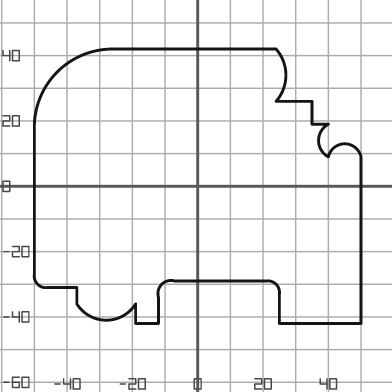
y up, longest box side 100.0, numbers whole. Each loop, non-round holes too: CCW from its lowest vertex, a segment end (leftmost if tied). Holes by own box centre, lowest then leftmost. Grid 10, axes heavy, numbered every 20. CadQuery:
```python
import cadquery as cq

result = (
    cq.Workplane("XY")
    .moveTo(-19.0, -42.0)
    .lineTo(-12.0, -42.0)
    .lineTo(-12.0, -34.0)
    .threePointArc((-11.0, -30.0), (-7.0, -29.0))
    .lineTo(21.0, -29.0)
    .threePointArc((24.0, -30.0), (25.0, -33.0))
    .lineTo(25.0, -42.0)
    .lineTo(50.0, -42.0)
    .lineTo(50.0, 9.0)
    .threePointArc((45.0, 13.0), (40.0, 9.0))
    .threePointArc((37.0, 14.0), (40.0, 19.0))
    .lineTo(35.0, 19.0)
    .lineTo(35.0, 26.0)
    .lineTo(24.0, 26.0)
    .threePointArc((27.0, 34.0), (24.0, 42.0))
    .lineTo(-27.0, 42.0)
    .threePointArc((-43.0, 35.0), (-50.0, 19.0))
    .lineTo(-50.0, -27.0)
    .threePointArc((-49.0, -30.0), (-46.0, -31.0))
    .lineTo(-37.0, -31.0)
    .lineTo(-37.0, -36.0)
    .threePointArc((-28.0, -41.0), (-19.0, -36.0))
    .close()
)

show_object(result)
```